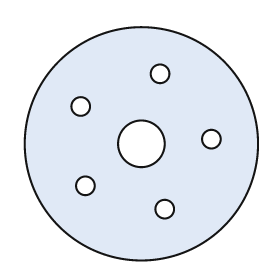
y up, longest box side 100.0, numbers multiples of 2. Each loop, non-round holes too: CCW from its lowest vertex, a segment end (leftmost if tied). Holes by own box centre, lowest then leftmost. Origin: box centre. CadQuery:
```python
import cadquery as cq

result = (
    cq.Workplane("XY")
    .moveTo(0.0, 0.0)
    .circle(50.0)
    .moveTo(10.0, -28.0)
    .circle(4.0)
    .moveTo(-24.0, -18.0)
    .circle(4.0)
    .moveTo(0.0, 0.0)
    .circle(10.0)
    .moveTo(30.0, 2.0)
    .circle(4.0)
    .moveTo(-26.0, 16.0)
    .circle(4.0)
    .moveTo(8.0, 30.0)
    .circle(4.0)
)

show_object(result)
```